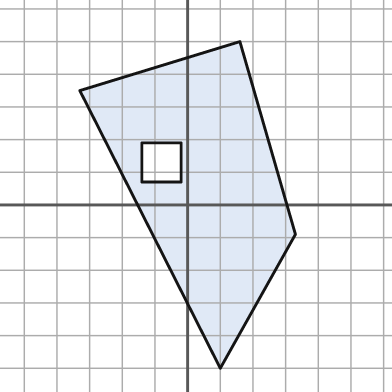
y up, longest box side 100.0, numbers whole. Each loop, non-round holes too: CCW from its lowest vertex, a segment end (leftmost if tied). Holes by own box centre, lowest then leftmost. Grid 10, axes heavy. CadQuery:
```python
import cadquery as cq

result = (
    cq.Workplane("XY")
    .moveTo(10.0, -50.0)
    .lineTo(33.0, -9.0)
    .lineTo(16.0, 50.0)
    .lineTo(-33.0, 35.0)
    .close()
    .moveTo(-14.0, 7.0)
    .lineTo(-2.0, 7.0)
    .lineTo(-2.0, 19.0)
    .lineTo(-14.0, 19.0)
    .close()
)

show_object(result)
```